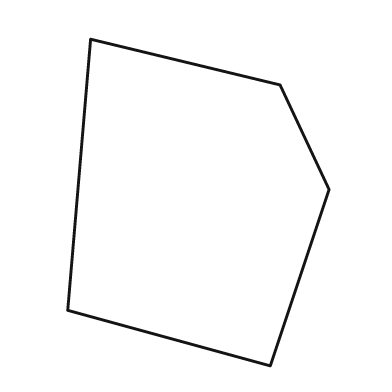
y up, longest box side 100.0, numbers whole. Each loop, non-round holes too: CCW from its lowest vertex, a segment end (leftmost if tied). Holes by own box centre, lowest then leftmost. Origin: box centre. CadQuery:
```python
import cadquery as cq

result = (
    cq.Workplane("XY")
    .moveTo(22.0, -50.0)
    .lineTo(40.0, 4.0)
    .lineTo(25.0, 36.0)
    .lineTo(-33.0, 50.0)
    .lineTo(-40.0, -33.0)
    .close()
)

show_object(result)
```